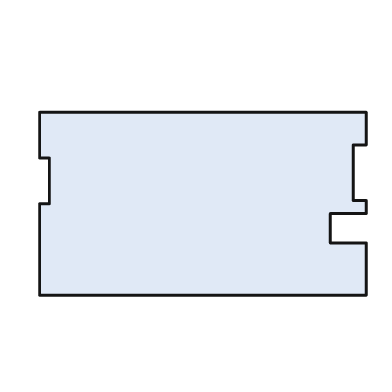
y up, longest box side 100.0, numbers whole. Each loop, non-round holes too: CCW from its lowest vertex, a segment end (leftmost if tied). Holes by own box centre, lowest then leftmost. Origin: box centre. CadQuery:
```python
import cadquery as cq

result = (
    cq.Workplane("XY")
    .moveTo(-50.0, -28.0)
    .lineTo(50.0, -28.0)
    .lineTo(50.0, -12.0)
    .lineTo(39.0, -12.0)
    .lineTo(39.0, -3.0)
    .lineTo(50.0, -3.0)
    .lineTo(50.0, 1.0)
    .lineTo(46.0, 1.0)
    .lineTo(46.0, 18.0)
    .lineTo(50.0, 18.0)
    .lineTo(50.0, 28.0)
    .lineTo(-50.0, 28.0)
    .lineTo(-50.0, 14.0)
    .lineTo(-47.0, 14.0)
    .lineTo(-47.0, 0.0)
    .lineTo(-50.0, 0.0)
    .close()
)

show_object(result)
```